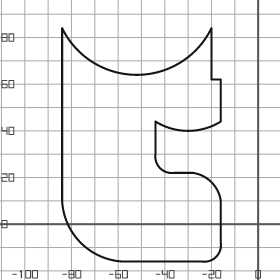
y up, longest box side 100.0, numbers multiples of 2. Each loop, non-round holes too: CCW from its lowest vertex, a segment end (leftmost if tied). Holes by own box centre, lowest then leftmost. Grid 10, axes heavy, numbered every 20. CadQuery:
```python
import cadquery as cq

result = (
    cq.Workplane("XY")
    .moveTo(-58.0, -16.0)
    .lineTo(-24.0, -16.0)
    .threePointArc((-18.0, -14.0), (-16.0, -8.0))
    .lineTo(-16.0, 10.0)
    .threePointArc((-20.0, 18.0), (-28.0, 22.0))
    .lineTo(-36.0, 22.0)
    .threePointArc((-42.0, 24.0), (-44.0, 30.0))
    .lineTo(-44.0, 44.0)
    .threePointArc((-30.0, 40.0), (-16.0, 44.0))
    .lineTo(-16.0, 62.0)
    .lineTo(-20.0, 62.0)
    .lineTo(-20.0, 84.0)
    .threePointArc((-52.0, 64.0), (-84.0, 84.0))
    .lineTo(-84.0, 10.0)
    .threePointArc((-76.0, -8.0), (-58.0, -16.0))
    .close()
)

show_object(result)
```